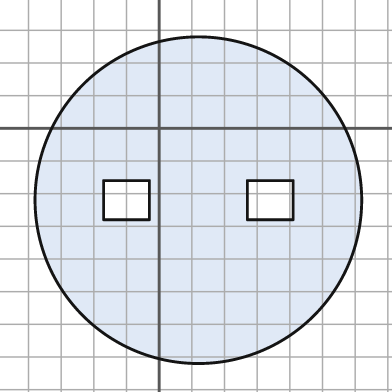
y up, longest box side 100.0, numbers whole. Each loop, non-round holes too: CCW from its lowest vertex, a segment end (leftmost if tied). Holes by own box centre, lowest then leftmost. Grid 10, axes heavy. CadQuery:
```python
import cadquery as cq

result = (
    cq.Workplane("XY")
    .moveTo(12.0, -22.0)
    .circle(50.0)
    .moveTo(-17.0, -28.0)
    .lineTo(-3.0, -28.0)
    .lineTo(-3.0, -16.0)
    .lineTo(-17.0, -16.0)
    .close()
    .moveTo(27.0, -28.0)
    .lineTo(41.0, -28.0)
    .lineTo(41.0, -16.0)
    .lineTo(27.0, -16.0)
    .close()
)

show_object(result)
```